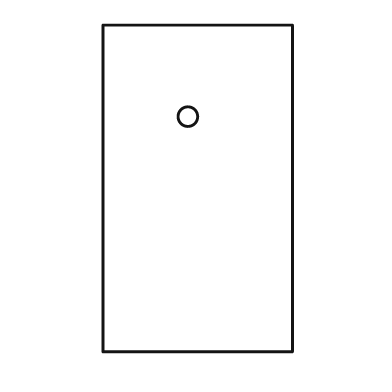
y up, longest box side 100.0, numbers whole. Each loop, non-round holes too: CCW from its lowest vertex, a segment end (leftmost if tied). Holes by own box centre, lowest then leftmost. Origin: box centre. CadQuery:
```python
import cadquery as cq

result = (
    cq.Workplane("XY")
    .moveTo(-29.0, -50.0)
    .lineTo(29.0, -50.0)
    .lineTo(29.0, 50.0)
    .lineTo(-29.0, 50.0)
    .close()
    .moveTo(-3.0, 22.0)
    .circle(3.0)
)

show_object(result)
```